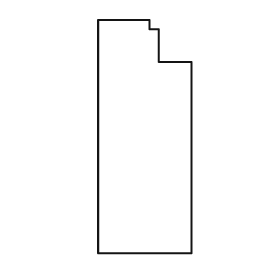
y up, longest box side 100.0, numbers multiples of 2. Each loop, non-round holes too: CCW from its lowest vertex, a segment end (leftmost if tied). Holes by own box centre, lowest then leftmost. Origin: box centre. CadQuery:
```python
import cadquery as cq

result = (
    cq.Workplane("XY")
    .moveTo(-20.0, -50.0)
    .lineTo(20.0, -50.0)
    .lineTo(20.0, 32.0)
    .lineTo(6.0, 32.0)
    .lineTo(6.0, 46.0)
    .lineTo(2.0, 46.0)
    .lineTo(2.0, 50.0)
    .lineTo(-20.0, 50.0)
    .close()
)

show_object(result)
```